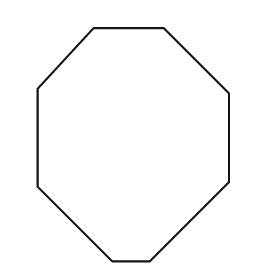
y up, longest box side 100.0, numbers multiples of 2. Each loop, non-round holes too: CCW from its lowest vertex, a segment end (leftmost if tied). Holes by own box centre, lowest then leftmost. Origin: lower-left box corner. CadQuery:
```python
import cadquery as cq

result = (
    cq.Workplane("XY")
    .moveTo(32.0, 0.0)
    .lineTo(48.0, 0.0)
    .lineTo(82.0, 34.0)
    .lineTo(82.0, 72.0)
    .lineTo(54.0, 100.0)
    .lineTo(24.0, 100.0)
    .lineTo(0.0, 74.0)
    .lineTo(0.0, 32.0)
    .close()
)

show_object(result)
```